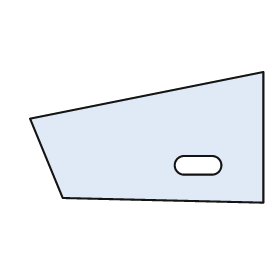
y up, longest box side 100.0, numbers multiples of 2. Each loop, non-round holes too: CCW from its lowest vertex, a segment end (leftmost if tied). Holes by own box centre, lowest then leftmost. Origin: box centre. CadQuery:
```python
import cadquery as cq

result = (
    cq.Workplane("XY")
    .moveTo(50.0, -28.0)
    .lineTo(50.0, 28.0)
    .lineTo(-50.0, 8.0)
    .lineTo(-36.0, -26.0)
    .close()
    .moveTo(16.0, -16.0)
    .lineTo(28.0, -16.0)
    .threePointArc((32.0, -12.0), (28.0, -8.0))
    .lineTo(16.0, -8.0)
    .threePointArc((12.0, -12.0), (16.0, -16.0))
    .close()
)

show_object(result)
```